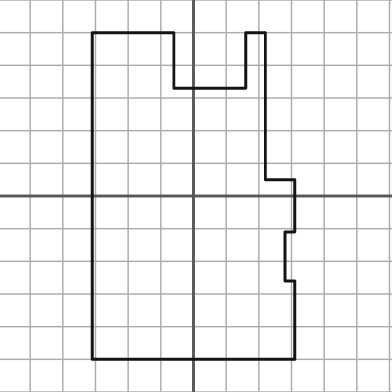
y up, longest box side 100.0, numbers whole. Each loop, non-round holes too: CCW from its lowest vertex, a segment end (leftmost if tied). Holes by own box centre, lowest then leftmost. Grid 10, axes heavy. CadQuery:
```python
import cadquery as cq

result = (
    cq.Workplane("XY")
    .moveTo(-31.0, -50.0)
    .lineTo(31.0, -50.0)
    .lineTo(31.0, -26.0)
    .lineTo(28.0, -26.0)
    .lineTo(28.0, -11.0)
    .lineTo(31.0, -11.0)
    .lineTo(31.0, 5.0)
    .lineTo(22.0, 5.0)
    .lineTo(22.0, 50.0)
    .lineTo(16.0, 50.0)
    .lineTo(16.0, 33.0)
    .lineTo(-6.0, 33.0)
    .lineTo(-6.0, 50.0)
    .lineTo(-31.0, 50.0)
    .close()
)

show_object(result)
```